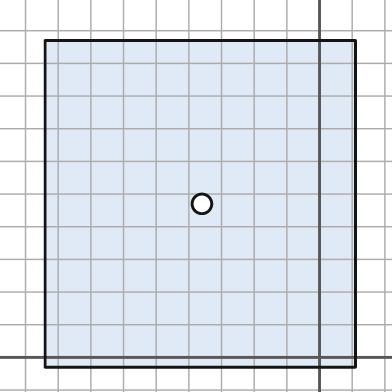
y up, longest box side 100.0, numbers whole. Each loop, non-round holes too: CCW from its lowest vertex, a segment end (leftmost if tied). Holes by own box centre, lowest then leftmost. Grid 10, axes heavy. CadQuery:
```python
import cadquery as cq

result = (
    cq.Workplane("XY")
    .moveTo(-84.0, -3.0)
    .lineTo(11.0, -3.0)
    .lineTo(11.0, 97.0)
    .lineTo(-84.0, 97.0)
    .close()
    .moveTo(-36.0, 47.0)
    .circle(3.0)
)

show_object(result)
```